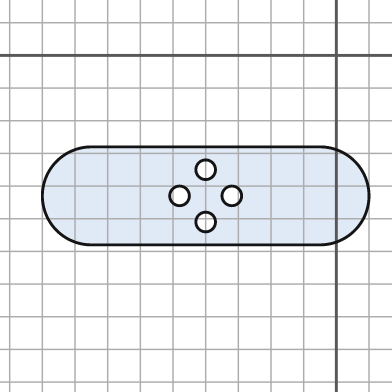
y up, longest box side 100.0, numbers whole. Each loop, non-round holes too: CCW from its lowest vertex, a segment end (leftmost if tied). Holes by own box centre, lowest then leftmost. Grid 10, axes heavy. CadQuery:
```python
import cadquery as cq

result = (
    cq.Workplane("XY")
    .moveTo(-75.0, -58.0)
    .lineTo(-5.0, -58.0)
    .threePointArc((10.0, -43.0), (-5.0, -28.0))
    .lineTo(-75.0, -28.0)
    .threePointArc((-90.0, -43.0), (-75.0, -58.0))
    .close()
    .moveTo(-40.0, -51.0)
    .circle(3.0)
    .moveTo(-48.0, -43.0)
    .circle(3.0)
    .moveTo(-32.0, -43.0)
    .circle(3.0)
    .moveTo(-40.0, -35.0)
    .circle(3.0)
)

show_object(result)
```